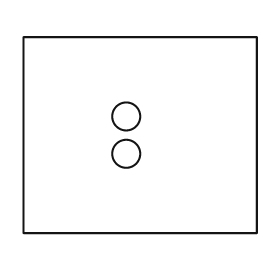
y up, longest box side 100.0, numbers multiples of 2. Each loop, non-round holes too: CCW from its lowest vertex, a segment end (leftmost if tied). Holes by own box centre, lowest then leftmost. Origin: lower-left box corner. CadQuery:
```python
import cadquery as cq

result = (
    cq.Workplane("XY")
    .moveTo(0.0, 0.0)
    .lineTo(100.0, 0.0)
    .lineTo(100.0, 84.0)
    .lineTo(0.0, 84.0)
    .close()
    .moveTo(44.0, 34.0)
    .circle(6.0)
    .moveTo(44.0, 50.0)
    .circle(6.0)
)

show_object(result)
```